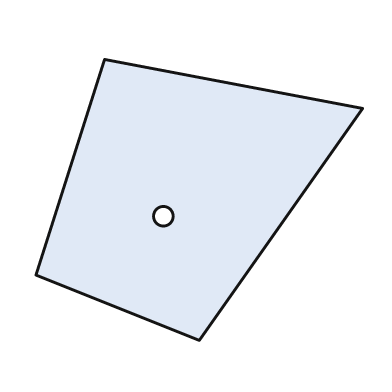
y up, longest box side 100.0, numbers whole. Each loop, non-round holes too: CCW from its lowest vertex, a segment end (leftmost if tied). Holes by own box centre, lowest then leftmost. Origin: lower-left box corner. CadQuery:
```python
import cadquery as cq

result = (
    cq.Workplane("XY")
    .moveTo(50.0, 0.0)
    .lineTo(100.0, 71.0)
    .lineTo(21.0, 86.0)
    .lineTo(0.0, 20.0)
    .close()
    .moveTo(39.0, 38.0)
    .circle(3.0)
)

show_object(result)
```